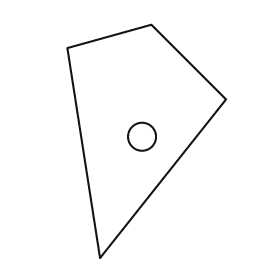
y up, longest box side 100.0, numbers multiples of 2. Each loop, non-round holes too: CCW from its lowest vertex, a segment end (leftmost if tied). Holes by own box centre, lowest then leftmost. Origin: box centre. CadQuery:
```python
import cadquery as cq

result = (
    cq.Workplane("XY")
    .moveTo(-20.0, -50.0)
    .lineTo(34.0, 18.0)
    .lineTo(2.0, 50.0)
    .lineTo(-34.0, 40.0)
    .close()
    .moveTo(-2.0, 2.0)
    .circle(6.0)
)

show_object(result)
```